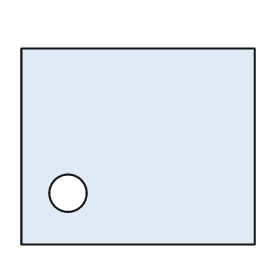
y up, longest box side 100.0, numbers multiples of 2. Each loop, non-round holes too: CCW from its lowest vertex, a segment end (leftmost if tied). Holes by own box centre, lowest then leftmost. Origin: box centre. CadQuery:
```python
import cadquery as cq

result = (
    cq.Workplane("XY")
    .moveTo(-50.0, -42.0)
    .lineTo(50.0, -42.0)
    .lineTo(50.0, 42.0)
    .lineTo(-50.0, 42.0)
    .close()
    .moveTo(-30.0, -20.0)
    .circle(8.0)
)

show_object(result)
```